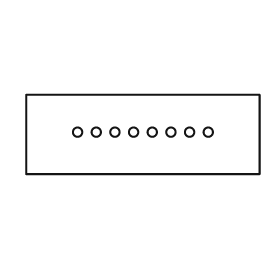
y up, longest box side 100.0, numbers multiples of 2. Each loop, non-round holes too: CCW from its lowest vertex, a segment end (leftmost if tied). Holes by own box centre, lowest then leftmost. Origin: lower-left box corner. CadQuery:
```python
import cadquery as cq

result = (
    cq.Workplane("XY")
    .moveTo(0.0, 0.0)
    .lineTo(100.0, 0.0)
    .lineTo(100.0, 34.0)
    .lineTo(0.0, 34.0)
    .close()
    .moveTo(22.0, 18.0)
    .circle(2.0)
    .moveTo(30.0, 18.0)
    .circle(2.0)
    .moveTo(38.0, 18.0)
    .circle(2.0)
    .moveTo(46.0, 18.0)
    .circle(2.0)
    .moveTo(54.0, 18.0)
    .circle(2.0)
    .moveTo(62.0, 18.0)
    .circle(2.0)
    .moveTo(70.0, 18.0)
    .circle(2.0)
    .moveTo(78.0, 18.0)
    .circle(2.0)
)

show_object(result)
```